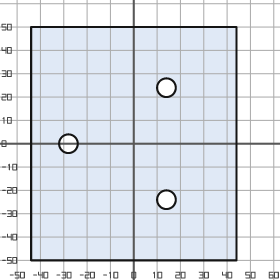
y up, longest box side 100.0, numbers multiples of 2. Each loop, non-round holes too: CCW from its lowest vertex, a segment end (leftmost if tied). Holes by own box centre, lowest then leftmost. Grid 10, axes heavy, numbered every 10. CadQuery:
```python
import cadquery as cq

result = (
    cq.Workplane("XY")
    .moveTo(-44.0, -50.0)
    .lineTo(44.0, -50.0)
    .lineTo(44.0, 50.0)
    .lineTo(-44.0, 50.0)
    .close()
    .moveTo(14.0, -24.0)
    .circle(4.0)
    .moveTo(-28.0, 0.0)
    .circle(4.0)
    .moveTo(14.0, 24.0)
    .circle(4.0)
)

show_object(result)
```